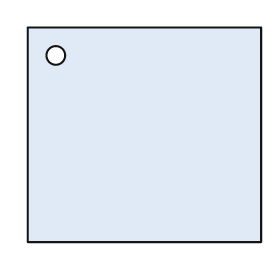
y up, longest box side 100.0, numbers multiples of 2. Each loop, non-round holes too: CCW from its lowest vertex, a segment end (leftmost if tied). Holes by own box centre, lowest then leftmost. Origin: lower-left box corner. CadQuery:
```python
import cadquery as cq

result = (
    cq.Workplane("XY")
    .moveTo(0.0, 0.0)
    .lineTo(100.0, 0.0)
    .lineTo(100.0, 92.0)
    .lineTo(0.0, 92.0)
    .close()
    .moveTo(12.0, 80.0)
    .circle(4.0)
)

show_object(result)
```